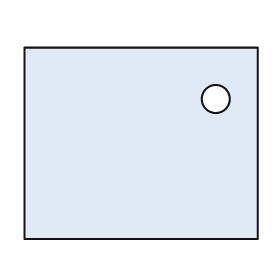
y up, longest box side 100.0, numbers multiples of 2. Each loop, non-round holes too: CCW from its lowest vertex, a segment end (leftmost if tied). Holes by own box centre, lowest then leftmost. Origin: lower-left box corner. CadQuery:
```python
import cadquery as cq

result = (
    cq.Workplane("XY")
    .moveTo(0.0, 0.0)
    .lineTo(100.0, 0.0)
    .lineTo(100.0, 82.0)
    .lineTo(0.0, 82.0)
    .close()
    .moveTo(82.0, 60.0)
    .circle(6.0)
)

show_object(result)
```